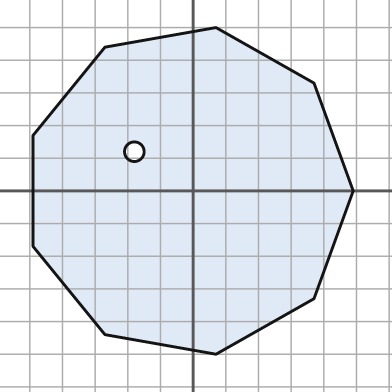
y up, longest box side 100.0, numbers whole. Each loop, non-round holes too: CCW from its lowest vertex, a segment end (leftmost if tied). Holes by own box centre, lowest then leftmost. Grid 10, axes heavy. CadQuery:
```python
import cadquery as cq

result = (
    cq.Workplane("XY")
    .moveTo(7.0, -50.0)
    .lineTo(37.0, -33.0)
    .lineTo(49.0, 0.0)
    .lineTo(37.0, 33.0)
    .lineTo(7.0, 50.0)
    .lineTo(-27.0, 44.0)
    .lineTo(-49.0, 17.0)
    .lineTo(-49.0, -17.0)
    .lineTo(-27.0, -44.0)
    .close()
    .moveTo(-18.0, 12.0)
    .circle(3.0)
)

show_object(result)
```